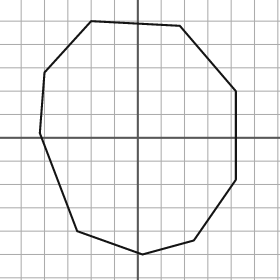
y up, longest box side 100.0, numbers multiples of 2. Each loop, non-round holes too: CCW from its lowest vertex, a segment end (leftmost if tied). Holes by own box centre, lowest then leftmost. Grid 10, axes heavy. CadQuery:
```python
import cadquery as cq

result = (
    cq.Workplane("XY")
    .moveTo(2.0, -50.0)
    .lineTo(24.0, -44.0)
    .lineTo(42.0, -18.0)
    .lineTo(42.0, 20.0)
    .lineTo(18.0, 48.0)
    .lineTo(-20.0, 50.0)
    .lineTo(-40.0, 28.0)
    .lineTo(-42.0, 2.0)
    .lineTo(-26.0, -40.0)
    .close()
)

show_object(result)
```